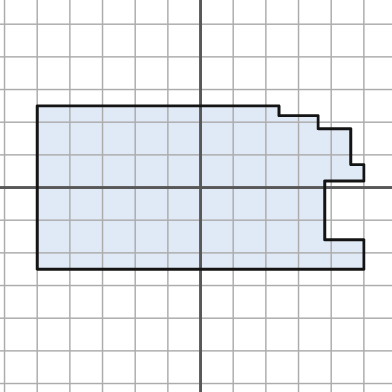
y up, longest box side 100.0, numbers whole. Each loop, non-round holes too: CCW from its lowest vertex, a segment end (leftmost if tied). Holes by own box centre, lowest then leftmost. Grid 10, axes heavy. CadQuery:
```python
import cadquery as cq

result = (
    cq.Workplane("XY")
    .moveTo(-50.0, -25.0)
    .lineTo(50.0, -25.0)
    .lineTo(50.0, -16.0)
    .lineTo(38.0, -16.0)
    .lineTo(38.0, 2.0)
    .lineTo(50.0, 2.0)
    .lineTo(50.0, 7.0)
    .lineTo(46.0, 7.0)
    .lineTo(46.0, 18.0)
    .lineTo(36.0, 18.0)
    .lineTo(36.0, 22.0)
    .lineTo(24.0, 22.0)
    .lineTo(24.0, 25.0)
    .lineTo(-50.0, 25.0)
    .close()
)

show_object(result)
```